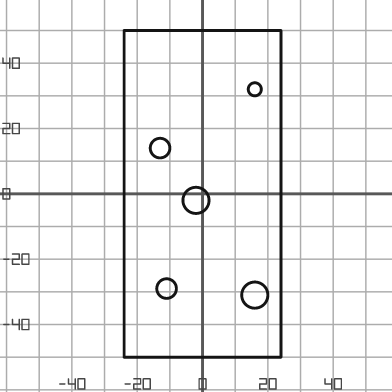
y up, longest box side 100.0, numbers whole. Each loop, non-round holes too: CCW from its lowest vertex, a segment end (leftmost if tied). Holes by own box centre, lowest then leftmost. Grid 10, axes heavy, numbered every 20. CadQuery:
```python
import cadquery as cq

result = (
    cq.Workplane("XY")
    .moveTo(-24.0, -50.0)
    .lineTo(24.0, -50.0)
    .lineTo(24.0, 50.0)
    .lineTo(-24.0, 50.0)
    .close()
    .moveTo(16.0, -31.0)
    .circle(4.0)
    .moveTo(-11.0, -29.0)
    .circle(3.0)
    .moveTo(-2.0, -2.0)
    .circle(4.0)
    .moveTo(-13.0, 14.0)
    .circle(3.0)
    .moveTo(16.0, 32.0)
    .circle(2.0)
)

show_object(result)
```